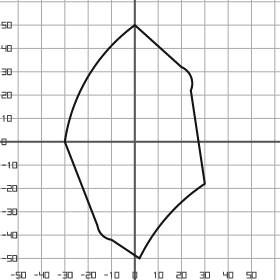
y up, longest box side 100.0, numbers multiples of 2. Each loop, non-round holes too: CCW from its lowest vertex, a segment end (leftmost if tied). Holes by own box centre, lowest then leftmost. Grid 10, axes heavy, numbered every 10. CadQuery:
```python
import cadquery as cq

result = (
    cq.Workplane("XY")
    .moveTo(2.0, -50.0)
    .threePointArc((14.0, -32.0), (30.0, -18.0))
    .lineTo(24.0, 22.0)
    .threePointArc((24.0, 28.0), (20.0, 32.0))
    .lineTo(0.0, 50.0)
    .threePointArc((-20.0, 28.0), (-30.0, 0.0))
    .lineTo(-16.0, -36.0)
    .threePointArc((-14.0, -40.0), (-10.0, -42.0))
    .close()
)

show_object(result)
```